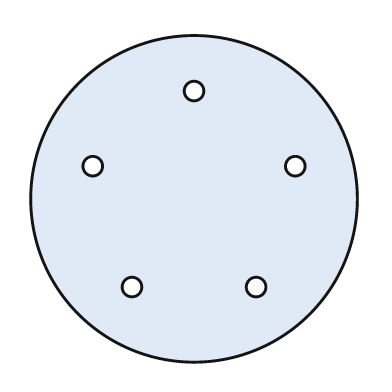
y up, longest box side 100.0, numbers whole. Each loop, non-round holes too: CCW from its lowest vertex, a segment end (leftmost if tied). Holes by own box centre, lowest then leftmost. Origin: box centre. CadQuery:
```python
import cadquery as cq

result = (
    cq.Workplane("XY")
    .moveTo(0.0, 0.0)
    .circle(50.0)
    .moveTo(-19.0, -27.0)
    .circle(3.0)
    .moveTo(19.0, -27.0)
    .circle(3.0)
    .moveTo(-31.0, 10.0)
    .circle(3.0)
    .moveTo(31.0, 10.0)
    .circle(3.0)
    .moveTo(0.0, 33.0)
    .circle(3.0)
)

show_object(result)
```